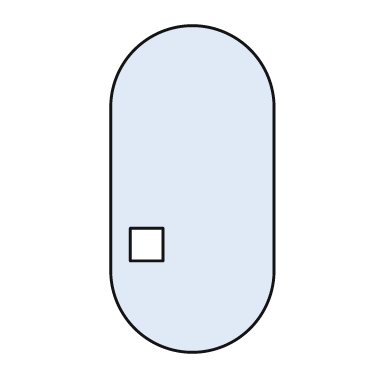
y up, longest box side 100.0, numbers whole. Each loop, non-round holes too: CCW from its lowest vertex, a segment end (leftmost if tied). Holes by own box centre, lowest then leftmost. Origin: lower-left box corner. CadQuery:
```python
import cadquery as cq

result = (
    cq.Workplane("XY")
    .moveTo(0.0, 25.0)
    .threePointArc((25.0, 0.0), (50.0, 25.0))
    .lineTo(50.0, 75.0)
    .threePointArc((25.0, 100.0), (0.0, 75.0))
    .close()
    .moveTo(6.0, 28.0)
    .lineTo(16.0, 28.0)
    .lineTo(16.0, 38.0)
    .lineTo(6.0, 38.0)
    .close()
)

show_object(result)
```